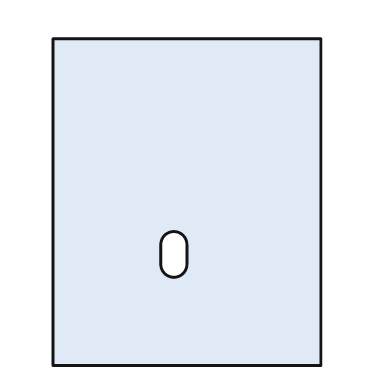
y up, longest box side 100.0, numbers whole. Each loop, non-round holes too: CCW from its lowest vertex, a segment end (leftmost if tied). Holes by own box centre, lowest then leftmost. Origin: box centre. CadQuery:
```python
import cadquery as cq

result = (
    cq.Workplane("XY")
    .moveTo(-41.0, -50.0)
    .lineTo(41.0, -50.0)
    .lineTo(41.0, 50.0)
    .lineTo(-41.0, 50.0)
    .close()
    .moveTo(-8.0, -19.0)
    .threePointArc((-4.0, -23.0), (0.0, -19.0))
    .lineTo(0.0, -13.0)
    .threePointArc((-4.0, -9.0), (-8.0, -13.0))
    .close()
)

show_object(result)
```